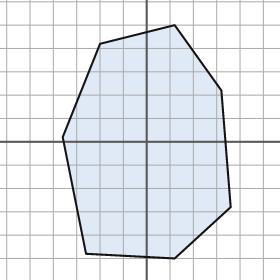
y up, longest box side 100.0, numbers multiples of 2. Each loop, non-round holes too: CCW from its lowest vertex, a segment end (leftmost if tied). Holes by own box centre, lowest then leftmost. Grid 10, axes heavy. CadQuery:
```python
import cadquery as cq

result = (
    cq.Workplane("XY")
    .moveTo(12.0, -50.0)
    .lineTo(36.0, -28.0)
    .lineTo(32.0, 22.0)
    .lineTo(12.0, 50.0)
    .lineTo(-20.0, 42.0)
    .lineTo(-36.0, 2.0)
    .lineTo(-26.0, -48.0)
    .close()
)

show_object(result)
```